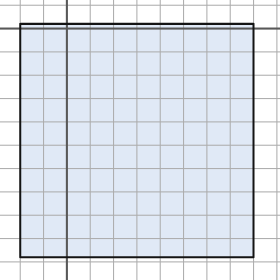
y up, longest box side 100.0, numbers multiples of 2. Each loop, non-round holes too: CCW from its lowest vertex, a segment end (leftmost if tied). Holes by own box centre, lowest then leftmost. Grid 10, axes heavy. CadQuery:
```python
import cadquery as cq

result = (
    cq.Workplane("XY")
    .moveTo(-20.0, -98.0)
    .lineTo(80.0, -98.0)
    .lineTo(80.0, 2.0)
    .lineTo(-20.0, 2.0)
    .close()
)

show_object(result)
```